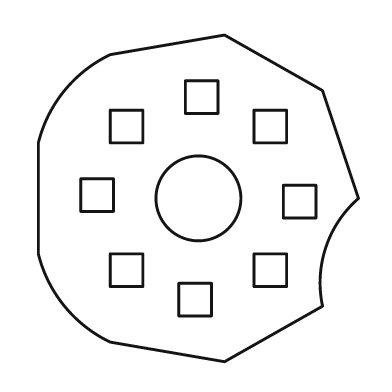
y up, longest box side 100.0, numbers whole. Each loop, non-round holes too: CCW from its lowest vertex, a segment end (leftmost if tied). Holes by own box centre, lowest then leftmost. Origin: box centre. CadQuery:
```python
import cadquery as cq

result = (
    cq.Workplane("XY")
    .moveTo(8.0, -50.0)
    .lineTo(38.0, -33.0)
    .threePointArc((39.0, -15.0), (49.0, 0.0))
    .lineTo(38.0, 33.0)
    .lineTo(8.0, 50.0)
    .lineTo(-27.0, 44.0)
    .threePointArc((-41.0, 33.0), (-49.0, 17.0))
    .lineTo(-49.0, -17.0)
    .threePointArc((-41.0, -33.0), (-27.0, -44.0))
    .close()
    .moveTo(-6.0, -36.0)
    .lineTo(4.0, -36.0)
    .lineTo(4.0, -26.0)
    .lineTo(-6.0, -26.0)
    .close()
    .moveTo(-27.0, -27.0)
    .lineTo(-17.0, -27.0)
    .lineTo(-17.0, -17.0)
    .lineTo(-27.0, -17.0)
    .close()
    .moveTo(17.0, -27.0)
    .lineTo(27.0, -27.0)
    .lineTo(27.0, -17.0)
    .lineTo(17.0, -17.0)
    .close()
    .moveTo(26.0, -6.0)
    .lineTo(36.0, -6.0)
    .lineTo(36.0, 4.0)
    .lineTo(26.0, 4.0)
    .close()
    .moveTo(0.0, 0.0)
    .circle(13.0)
    .moveTo(-36.0, -4.0)
    .lineTo(-26.0, -4.0)
    .lineTo(-26.0, 6.0)
    .lineTo(-36.0, 6.0)
    .close()
    .moveTo(-27.0, 17.0)
    .lineTo(-17.0, 17.0)
    .lineTo(-17.0, 27.0)
    .lineTo(-27.0, 27.0)
    .close()
    .moveTo(17.0, 17.0)
    .lineTo(27.0, 17.0)
    .lineTo(27.0, 27.0)
    .lineTo(17.0, 27.0)
    .close()
    .moveTo(-4.0, 26.0)
    .lineTo(6.0, 26.0)
    .lineTo(6.0, 36.0)
    .lineTo(-4.0, 36.0)
    .close()
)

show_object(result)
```